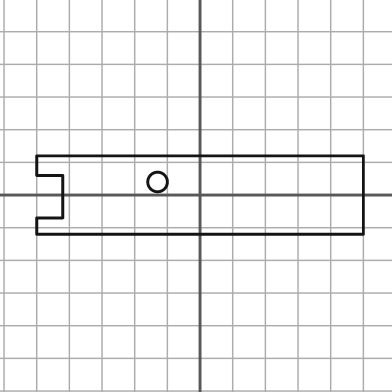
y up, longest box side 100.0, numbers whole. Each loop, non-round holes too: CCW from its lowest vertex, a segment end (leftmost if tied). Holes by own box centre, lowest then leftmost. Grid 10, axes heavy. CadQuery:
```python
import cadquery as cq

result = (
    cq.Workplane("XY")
    .moveTo(-50.0, -12.0)
    .lineTo(50.0, -12.0)
    .lineTo(50.0, 12.0)
    .lineTo(-50.0, 12.0)
    .lineTo(-50.0, 6.0)
    .lineTo(-42.0, 6.0)
    .lineTo(-42.0, -7.0)
    .lineTo(-50.0, -7.0)
    .close()
    .moveTo(-13.0, 4.0)
    .circle(3.0)
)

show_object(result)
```